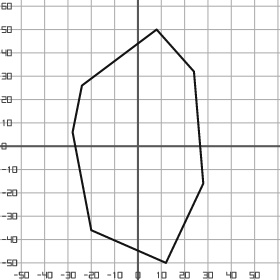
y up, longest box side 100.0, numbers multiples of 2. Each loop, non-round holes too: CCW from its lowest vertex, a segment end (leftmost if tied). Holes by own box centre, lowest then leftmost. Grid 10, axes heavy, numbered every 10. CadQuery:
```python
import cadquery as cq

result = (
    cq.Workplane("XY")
    .moveTo(12.0, -50.0)
    .lineTo(28.0, -16.0)
    .lineTo(24.0, 32.0)
    .lineTo(8.0, 50.0)
    .lineTo(-24.0, 26.0)
    .lineTo(-28.0, 6.0)
    .lineTo(-20.0, -36.0)
    .close()
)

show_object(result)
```